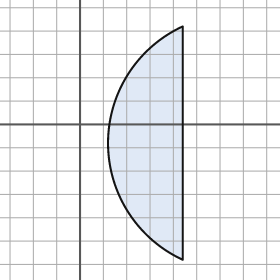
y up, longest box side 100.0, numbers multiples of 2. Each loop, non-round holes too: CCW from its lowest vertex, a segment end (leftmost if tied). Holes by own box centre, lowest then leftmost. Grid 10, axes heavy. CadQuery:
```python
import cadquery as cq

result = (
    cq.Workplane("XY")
    .moveTo(44.0, -58.0)
    .lineTo(44.0, 42.0)
    .threePointArc((12.0, -8.0), (44.0, -58.0))
    .close()
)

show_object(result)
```